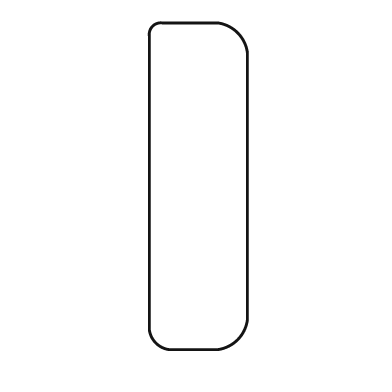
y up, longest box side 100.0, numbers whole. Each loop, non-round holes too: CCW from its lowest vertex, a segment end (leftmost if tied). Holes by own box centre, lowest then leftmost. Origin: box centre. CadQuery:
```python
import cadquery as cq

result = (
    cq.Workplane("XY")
    .moveTo(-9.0, -50.0)
    .lineTo(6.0, -50.0)
    .threePointArc((12.0, -47.0), (15.0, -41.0))
    .lineTo(15.0, 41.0)
    .threePointArc((12.0, 47.0), (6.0, 50.0))
    .lineTo(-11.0, 50.0)
    .threePointArc((-14.0, 49.0), (-15.0, 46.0))
    .lineTo(-15.0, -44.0)
    .threePointArc((-13.0, -48.0), (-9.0, -50.0))
    .close()
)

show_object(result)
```